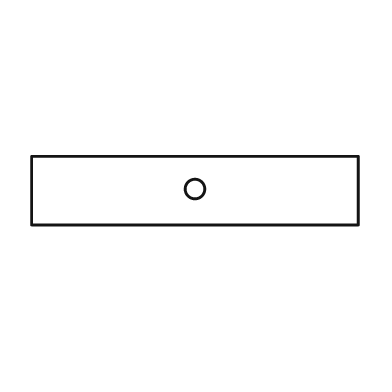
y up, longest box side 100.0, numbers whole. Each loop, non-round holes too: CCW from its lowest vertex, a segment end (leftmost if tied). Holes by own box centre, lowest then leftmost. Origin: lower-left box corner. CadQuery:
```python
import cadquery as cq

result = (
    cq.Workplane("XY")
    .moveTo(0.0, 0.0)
    .lineTo(100.0, 0.0)
    .lineTo(100.0, 21.0)
    .lineTo(0.0, 21.0)
    .close()
    .moveTo(50.0, 11.0)
    .circle(3.0)
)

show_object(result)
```